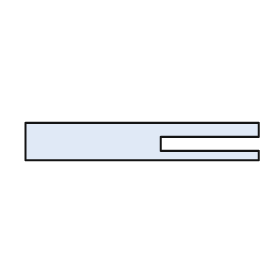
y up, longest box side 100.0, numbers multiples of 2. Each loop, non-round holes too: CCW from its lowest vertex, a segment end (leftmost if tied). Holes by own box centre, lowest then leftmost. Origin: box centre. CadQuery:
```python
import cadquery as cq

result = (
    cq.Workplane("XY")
    .moveTo(-50.0, -8.0)
    .lineTo(50.0, -8.0)
    .lineTo(50.0, -4.0)
    .lineTo(8.0, -4.0)
    .lineTo(8.0, 2.0)
    .lineTo(50.0, 2.0)
    .lineTo(50.0, 8.0)
    .lineTo(-50.0, 8.0)
    .close()
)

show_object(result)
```